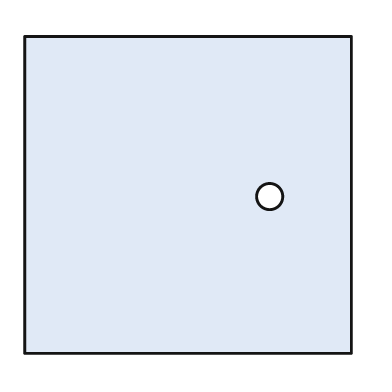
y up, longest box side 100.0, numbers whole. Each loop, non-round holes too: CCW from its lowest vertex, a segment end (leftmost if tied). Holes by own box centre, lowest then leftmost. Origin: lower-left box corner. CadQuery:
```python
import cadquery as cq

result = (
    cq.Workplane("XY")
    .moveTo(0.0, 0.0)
    .lineTo(100.0, 0.0)
    .lineTo(100.0, 97.0)
    .lineTo(0.0, 97.0)
    .close()
    .moveTo(75.0, 48.0)
    .circle(4.0)
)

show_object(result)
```